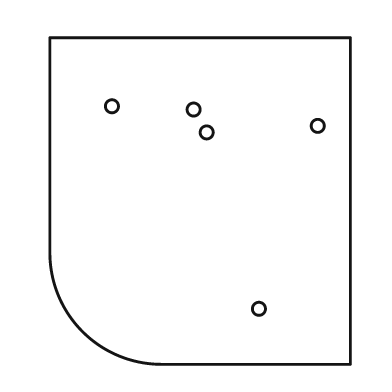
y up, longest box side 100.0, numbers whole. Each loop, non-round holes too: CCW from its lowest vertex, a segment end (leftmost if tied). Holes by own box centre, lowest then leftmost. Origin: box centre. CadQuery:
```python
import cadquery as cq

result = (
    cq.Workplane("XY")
    .moveTo(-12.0, -50.0)
    .lineTo(46.0, -50.0)
    .lineTo(46.0, 50.0)
    .lineTo(-46.0, 50.0)
    .lineTo(-46.0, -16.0)
    .threePointArc((-36.0, -40.0), (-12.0, -50.0))
    .close()
    .moveTo(18.0, -33.0)
    .circle(2.0)
    .moveTo(2.0, 21.0)
    .circle(2.0)
    .moveTo(36.0, 23.0)
    .circle(2.0)
    .moveTo(-2.0, 28.0)
    .circle(2.0)
    .moveTo(-27.0, 29.0)
    .circle(2.0)
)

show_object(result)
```